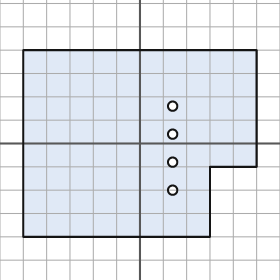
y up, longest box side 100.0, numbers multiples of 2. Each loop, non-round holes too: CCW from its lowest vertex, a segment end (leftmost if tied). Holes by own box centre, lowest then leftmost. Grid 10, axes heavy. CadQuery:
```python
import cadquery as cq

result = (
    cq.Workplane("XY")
    .moveTo(-50.0, -40.0)
    .lineTo(30.0, -40.0)
    .lineTo(30.0, -10.0)
    .lineTo(50.0, -10.0)
    .lineTo(50.0, 40.0)
    .lineTo(-50.0, 40.0)
    .close()
    .moveTo(14.0, -20.0)
    .circle(2.0)
    .moveTo(14.0, -8.0)
    .circle(2.0)
    .moveTo(14.0, 4.0)
    .circle(2.0)
    .moveTo(14.0, 16.0)
    .circle(2.0)
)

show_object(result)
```